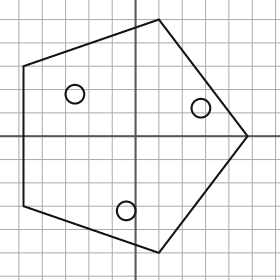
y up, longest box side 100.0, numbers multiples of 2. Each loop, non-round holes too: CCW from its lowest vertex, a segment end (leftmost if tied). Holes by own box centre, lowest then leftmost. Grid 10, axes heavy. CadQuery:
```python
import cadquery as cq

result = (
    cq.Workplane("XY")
    .moveTo(10.0, -50.0)
    .lineTo(48.0, 0.0)
    .lineTo(10.0, 50.0)
    .lineTo(-48.0, 30.0)
    .lineTo(-48.0, -30.0)
    .close()
    .moveTo(-4.0, -32.0)
    .circle(4.0)
    .moveTo(28.0, 12.0)
    .circle(4.0)
    .moveTo(-26.0, 18.0)
    .circle(4.0)
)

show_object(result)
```